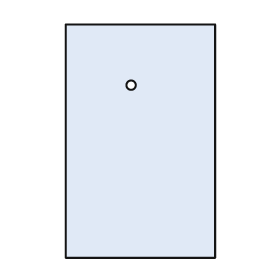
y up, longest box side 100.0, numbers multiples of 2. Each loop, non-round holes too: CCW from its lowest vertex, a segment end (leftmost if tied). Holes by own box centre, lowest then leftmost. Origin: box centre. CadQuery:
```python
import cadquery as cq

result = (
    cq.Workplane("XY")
    .moveTo(-32.0, -50.0)
    .lineTo(32.0, -50.0)
    .lineTo(32.0, 50.0)
    .lineTo(-32.0, 50.0)
    .close()
    .moveTo(-4.0, 24.0)
    .circle(2.0)
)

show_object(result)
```